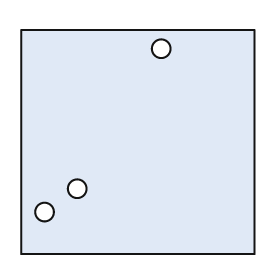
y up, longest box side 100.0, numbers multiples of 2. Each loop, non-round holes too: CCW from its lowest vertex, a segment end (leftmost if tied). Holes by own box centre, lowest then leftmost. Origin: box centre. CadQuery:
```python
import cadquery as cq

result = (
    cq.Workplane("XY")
    .moveTo(-50.0, -48.0)
    .lineTo(50.0, -48.0)
    .lineTo(50.0, 48.0)
    .lineTo(-50.0, 48.0)
    .close()
    .moveTo(-40.0, -30.0)
    .circle(4.0)
    .moveTo(-26.0, -20.0)
    .circle(4.0)
    .moveTo(10.0, 40.0)
    .circle(4.0)
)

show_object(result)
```